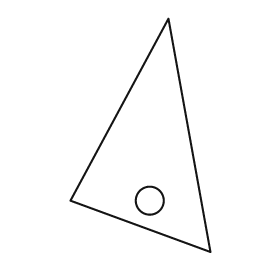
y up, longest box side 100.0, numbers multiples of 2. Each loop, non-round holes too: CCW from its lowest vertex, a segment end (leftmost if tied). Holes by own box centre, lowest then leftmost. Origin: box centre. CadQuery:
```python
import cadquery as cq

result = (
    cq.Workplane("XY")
    .moveTo(30.0, -50.0)
    .lineTo(12.0, 50.0)
    .lineTo(-30.0, -28.0)
    .close()
    .moveTo(4.0, -28.0)
    .circle(6.0)
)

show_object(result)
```